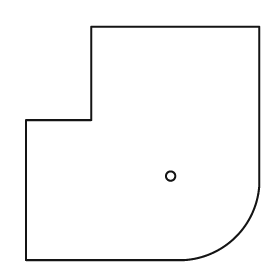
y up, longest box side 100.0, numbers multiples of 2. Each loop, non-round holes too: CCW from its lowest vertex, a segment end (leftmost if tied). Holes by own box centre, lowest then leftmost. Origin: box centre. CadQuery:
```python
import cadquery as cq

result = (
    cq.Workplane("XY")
    .moveTo(-50.0, -50.0)
    .lineTo(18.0, -50.0)
    .threePointArc((40.0, -40.0), (50.0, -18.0))
    .lineTo(50.0, 50.0)
    .lineTo(-22.0, 50.0)
    .lineTo(-22.0, 10.0)
    .lineTo(-50.0, 10.0)
    .close()
    .moveTo(12.0, -14.0)
    .circle(2.0)
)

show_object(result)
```